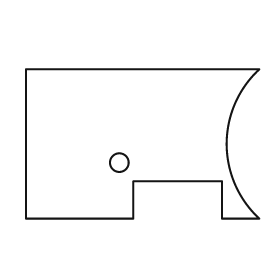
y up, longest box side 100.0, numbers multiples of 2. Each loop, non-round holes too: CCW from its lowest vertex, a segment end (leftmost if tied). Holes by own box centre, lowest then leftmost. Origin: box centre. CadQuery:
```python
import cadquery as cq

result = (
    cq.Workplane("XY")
    .moveTo(-50.0, -32.0)
    .lineTo(-4.0, -32.0)
    .lineTo(-4.0, -16.0)
    .lineTo(34.0, -16.0)
    .lineTo(34.0, -32.0)
    .lineTo(50.0, -32.0)
    .threePointArc((36.0, 0.0), (50.0, 32.0))
    .lineTo(-50.0, 32.0)
    .close()
    .moveTo(-10.0, -8.0)
    .circle(4.0)
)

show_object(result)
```